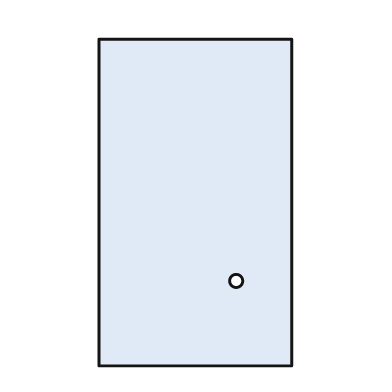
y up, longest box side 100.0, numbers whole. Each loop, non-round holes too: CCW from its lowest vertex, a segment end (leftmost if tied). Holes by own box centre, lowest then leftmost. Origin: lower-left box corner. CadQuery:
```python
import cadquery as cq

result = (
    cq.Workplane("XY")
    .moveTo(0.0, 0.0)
    .lineTo(59.0, 0.0)
    .lineTo(59.0, 100.0)
    .lineTo(0.0, 100.0)
    .close()
    .moveTo(42.0, 26.0)
    .circle(2.0)
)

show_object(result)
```